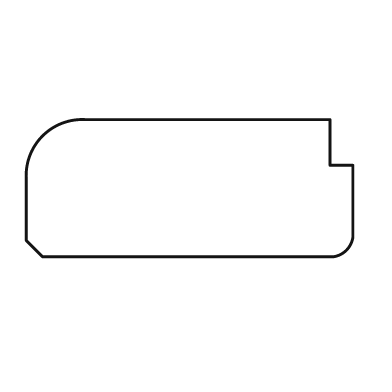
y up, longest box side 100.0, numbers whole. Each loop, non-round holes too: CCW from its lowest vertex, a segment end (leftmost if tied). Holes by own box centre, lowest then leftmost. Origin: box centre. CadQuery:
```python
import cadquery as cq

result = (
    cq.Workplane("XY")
    .moveTo(-45.0, -21.0)
    .lineTo(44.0, -21.0)
    .threePointArc((48.0, -19.0), (50.0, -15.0))
    .lineTo(50.0, 7.0)
    .lineTo(43.0, 7.0)
    .lineTo(43.0, 21.0)
    .lineTo(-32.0, 21.0)
    .threePointArc((-45.0, 16.0), (-50.0, 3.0))
    .lineTo(-50.0, -16.0)
    .close()
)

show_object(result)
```